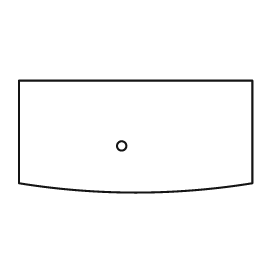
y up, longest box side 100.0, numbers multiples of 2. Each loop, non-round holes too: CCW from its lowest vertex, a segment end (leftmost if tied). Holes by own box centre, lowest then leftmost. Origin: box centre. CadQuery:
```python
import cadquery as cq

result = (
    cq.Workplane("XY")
    .moveTo(-50.0, -20.0)
    .threePointArc((0.0, -24.0), (50.0, -20.0))
    .lineTo(50.0, 24.0)
    .lineTo(-50.0, 24.0)
    .close()
    .moveTo(-6.0, -4.0)
    .circle(2.0)
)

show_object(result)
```